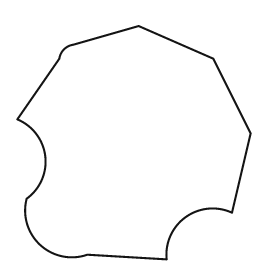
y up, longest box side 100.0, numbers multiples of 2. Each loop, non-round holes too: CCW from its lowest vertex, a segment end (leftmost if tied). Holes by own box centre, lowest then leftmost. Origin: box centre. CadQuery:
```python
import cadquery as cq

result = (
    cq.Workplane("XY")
    .moveTo(14.0, -50.0)
    .threePointArc((22.0, -32.0), (42.0, -30.0))
    .lineTo(50.0, 4.0)
    .lineTo(34.0, 36.0)
    .lineTo(2.0, 50.0)
    .lineTo(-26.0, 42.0)
    .threePointArc((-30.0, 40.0), (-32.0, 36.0))
    .lineTo(-50.0, 10.0)
    .threePointArc((-38.0, -6.0), (-46.0, -24.0))
    .threePointArc((-40.0, -44.0), (-20.0, -48.0))
    .close()
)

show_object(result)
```